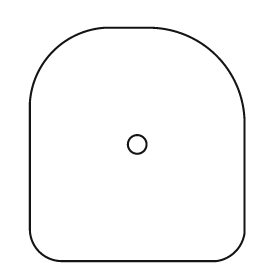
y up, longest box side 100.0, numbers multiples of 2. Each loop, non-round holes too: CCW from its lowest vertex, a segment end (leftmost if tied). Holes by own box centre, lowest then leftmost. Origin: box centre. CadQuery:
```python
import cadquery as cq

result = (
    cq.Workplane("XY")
    .moveTo(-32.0, -50.0)
    .lineTo(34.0, -50.0)
    .threePointArc((42.0, -46.0), (46.0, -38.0))
    .lineTo(46.0, 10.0)
    .threePointArc((34.0, 38.0), (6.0, 50.0))
    .lineTo(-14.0, 50.0)
    .threePointArc((-36.0, 40.0), (-46.0, 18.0))
    .lineTo(-46.0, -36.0)
    .threePointArc((-42.0, -46.0), (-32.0, -50.0))
    .close()
    .moveTo(0.0, 0.0)
    .circle(4.0)
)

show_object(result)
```